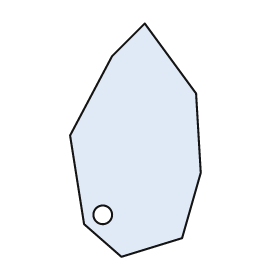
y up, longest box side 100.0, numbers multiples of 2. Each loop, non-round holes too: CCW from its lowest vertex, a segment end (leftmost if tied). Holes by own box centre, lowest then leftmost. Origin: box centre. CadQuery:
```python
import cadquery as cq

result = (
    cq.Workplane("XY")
    .moveTo(-6.0, -50.0)
    .lineTo(20.0, -42.0)
    .lineTo(28.0, -14.0)
    .lineTo(26.0, 20.0)
    .lineTo(4.0, 50.0)
    .lineTo(-10.0, 36.0)
    .lineTo(-28.0, 2.0)
    .lineTo(-22.0, -36.0)
    .close()
    .moveTo(-14.0, -32.0)
    .circle(4.0)
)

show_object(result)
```